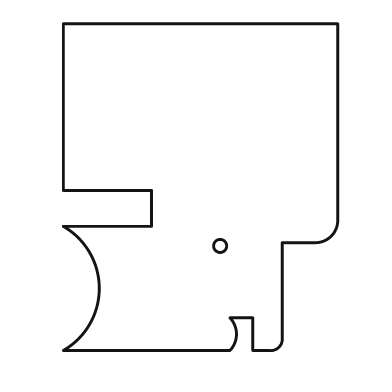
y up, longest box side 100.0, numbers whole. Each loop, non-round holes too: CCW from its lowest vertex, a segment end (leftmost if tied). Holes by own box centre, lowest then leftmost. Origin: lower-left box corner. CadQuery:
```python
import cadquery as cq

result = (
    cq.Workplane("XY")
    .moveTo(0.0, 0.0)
    .lineTo(51.0, 0.0)
    .threePointArc((53.0, 5.0), (51.0, 10.0))
    .lineTo(58.0, 10.0)
    .lineTo(58.0, 0.0)
    .lineTo(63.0, 0.0)
    .threePointArc((66.0, 1.0), (67.0, 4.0))
    .lineTo(67.0, 33.0)
    .lineTo(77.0, 33.0)
    .threePointArc((82.0, 35.0), (84.0, 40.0))
    .lineTo(84.0, 100.0)
    .lineTo(0.0, 100.0)
    .lineTo(0.0, 49.0)
    .lineTo(27.0, 49.0)
    .lineTo(27.0, 38.0)
    .lineTo(0.0, 38.0)
    .threePointArc((11.0, 19.0), (0.0, 0.0))
    .close()
    .moveTo(48.0, 32.0)
    .circle(2.0)
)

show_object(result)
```